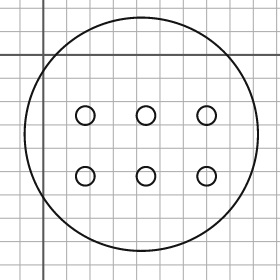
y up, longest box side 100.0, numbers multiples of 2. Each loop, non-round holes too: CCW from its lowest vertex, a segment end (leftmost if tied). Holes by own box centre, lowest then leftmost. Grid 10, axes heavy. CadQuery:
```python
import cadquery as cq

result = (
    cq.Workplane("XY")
    .moveTo(42.0, -34.0)
    .circle(50.0)
    .moveTo(18.0, -52.0)
    .circle(4.0)
    .moveTo(44.0, -52.0)
    .circle(4.0)
    .moveTo(70.0, -52.0)
    .circle(4.0)
    .moveTo(18.0, -26.0)
    .circle(4.0)
    .moveTo(44.0, -26.0)
    .circle(4.0)
    .moveTo(70.0, -26.0)
    .circle(4.0)
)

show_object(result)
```